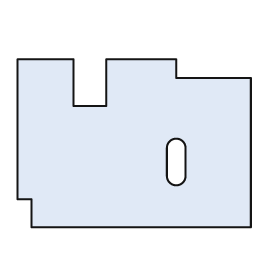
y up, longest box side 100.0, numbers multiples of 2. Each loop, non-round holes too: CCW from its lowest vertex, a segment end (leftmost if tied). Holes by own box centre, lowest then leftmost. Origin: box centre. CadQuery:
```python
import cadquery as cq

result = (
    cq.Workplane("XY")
    .moveTo(-44.0, -36.0)
    .lineTo(50.0, -36.0)
    .lineTo(50.0, 28.0)
    .lineTo(18.0, 28.0)
    .lineTo(18.0, 36.0)
    .lineTo(-12.0, 36.0)
    .lineTo(-12.0, 16.0)
    .lineTo(-26.0, 16.0)
    .lineTo(-26.0, 36.0)
    .lineTo(-50.0, 36.0)
    .lineTo(-50.0, -24.0)
    .lineTo(-44.0, -24.0)
    .close()
    .moveTo(14.0, -14.0)
    .threePointArc((18.0, -18.0), (22.0, -14.0))
    .lineTo(22.0, -2.0)
    .threePointArc((18.0, 2.0), (14.0, -2.0))
    .close()
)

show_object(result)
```